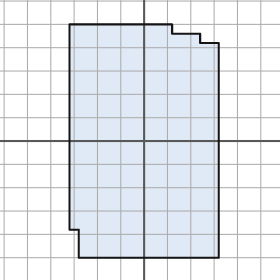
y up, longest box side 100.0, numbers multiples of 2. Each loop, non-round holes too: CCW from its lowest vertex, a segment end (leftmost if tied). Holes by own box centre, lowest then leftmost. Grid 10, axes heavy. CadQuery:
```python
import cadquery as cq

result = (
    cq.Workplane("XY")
    .moveTo(-28.0, -50.0)
    .lineTo(32.0, -50.0)
    .lineTo(32.0, 42.0)
    .lineTo(24.0, 42.0)
    .lineTo(24.0, 46.0)
    .lineTo(12.0, 46.0)
    .lineTo(12.0, 50.0)
    .lineTo(-32.0, 50.0)
    .lineTo(-32.0, -38.0)
    .lineTo(-28.0, -38.0)
    .close()
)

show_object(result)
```